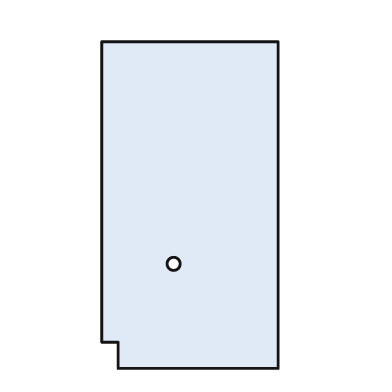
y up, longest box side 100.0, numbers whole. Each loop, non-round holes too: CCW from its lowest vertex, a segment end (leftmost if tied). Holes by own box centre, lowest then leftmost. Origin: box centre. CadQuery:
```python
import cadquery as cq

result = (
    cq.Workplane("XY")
    .moveTo(-22.0, -50.0)
    .lineTo(27.0, -50.0)
    .lineTo(27.0, 50.0)
    .lineTo(-27.0, 50.0)
    .lineTo(-27.0, -42.0)
    .lineTo(-22.0, -42.0)
    .close()
    .moveTo(-5.0, -18.0)
    .circle(2.0)
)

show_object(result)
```